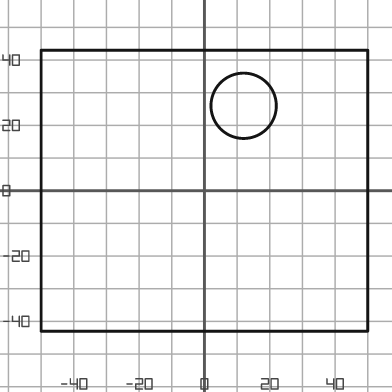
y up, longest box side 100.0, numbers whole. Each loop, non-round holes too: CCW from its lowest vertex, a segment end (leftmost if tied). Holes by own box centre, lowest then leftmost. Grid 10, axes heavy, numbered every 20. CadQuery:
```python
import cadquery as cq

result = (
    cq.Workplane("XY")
    .moveTo(-50.0, -43.0)
    .lineTo(50.0, -43.0)
    .lineTo(50.0, 43.0)
    .lineTo(-50.0, 43.0)
    .close()
    .moveTo(12.0, 26.0)
    .circle(10.0)
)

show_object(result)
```